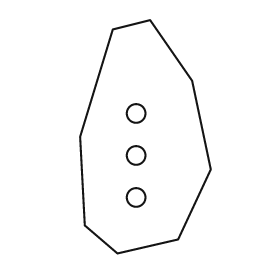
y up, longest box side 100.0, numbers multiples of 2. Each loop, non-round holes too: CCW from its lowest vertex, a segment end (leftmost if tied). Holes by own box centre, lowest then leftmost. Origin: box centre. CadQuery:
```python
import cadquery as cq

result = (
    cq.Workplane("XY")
    .moveTo(-12.0, -50.0)
    .lineTo(14.0, -44.0)
    .lineTo(28.0, -14.0)
    .lineTo(20.0, 24.0)
    .lineTo(2.0, 50.0)
    .lineTo(-14.0, 46.0)
    .lineTo(-28.0, 0.0)
    .lineTo(-26.0, -38.0)
    .close()
    .moveTo(-4.0, -26.0)
    .circle(4.0)
    .moveTo(-4.0, -8.0)
    .circle(4.0)
    .moveTo(-4.0, 10.0)
    .circle(4.0)
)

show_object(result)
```